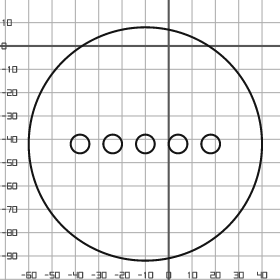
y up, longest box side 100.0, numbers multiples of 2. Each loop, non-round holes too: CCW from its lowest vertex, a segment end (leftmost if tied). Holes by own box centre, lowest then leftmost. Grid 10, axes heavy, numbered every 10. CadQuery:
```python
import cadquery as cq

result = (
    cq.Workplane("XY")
    .moveTo(-10.0, -42.0)
    .circle(50.0)
    .moveTo(-38.0, -42.0)
    .circle(4.0)
    .moveTo(-24.0, -42.0)
    .circle(4.0)
    .moveTo(-10.0, -42.0)
    .circle(4.0)
    .moveTo(4.0, -42.0)
    .circle(4.0)
    .moveTo(18.0, -42.0)
    .circle(4.0)
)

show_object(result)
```